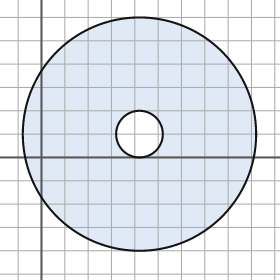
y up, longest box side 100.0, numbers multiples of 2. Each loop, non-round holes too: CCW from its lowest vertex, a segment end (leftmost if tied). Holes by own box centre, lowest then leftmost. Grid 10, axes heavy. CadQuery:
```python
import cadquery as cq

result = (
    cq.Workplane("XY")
    .moveTo(42.0, 10.0)
    .circle(50.0)
    .moveTo(42.0, 10.0)
    .circle(10.0)
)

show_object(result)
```